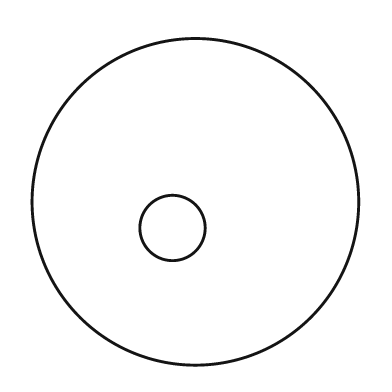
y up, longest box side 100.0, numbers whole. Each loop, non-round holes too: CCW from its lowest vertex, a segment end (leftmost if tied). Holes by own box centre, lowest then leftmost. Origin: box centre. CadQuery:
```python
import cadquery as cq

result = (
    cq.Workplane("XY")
    .moveTo(0.0, 0.0)
    .circle(50.0)
    .moveTo(-7.0, -8.0)
    .circle(10.0)
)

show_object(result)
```